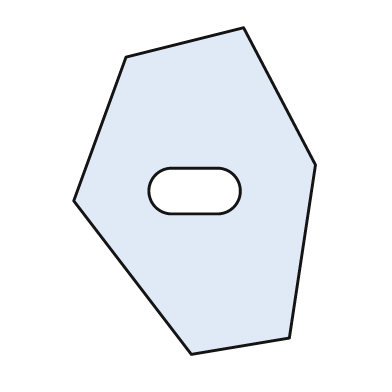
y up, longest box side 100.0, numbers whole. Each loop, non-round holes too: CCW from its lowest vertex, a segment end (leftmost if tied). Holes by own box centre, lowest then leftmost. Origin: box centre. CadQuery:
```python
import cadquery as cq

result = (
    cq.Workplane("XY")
    .moveTo(-1.0, -50.0)
    .lineTo(29.0, -45.0)
    .lineTo(37.0, 8.0)
    .lineTo(15.0, 50.0)
    .lineTo(-21.0, 41.0)
    .lineTo(-37.0, -3.0)
    .close()
    .moveTo(-7.0, -7.0)
    .lineTo(7.0, -7.0)
    .threePointArc((14.0, 0.0), (7.0, 7.0))
    .lineTo(-7.0, 7.0)
    .threePointArc((-14.0, 0.0), (-7.0, -7.0))
    .close()
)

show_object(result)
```